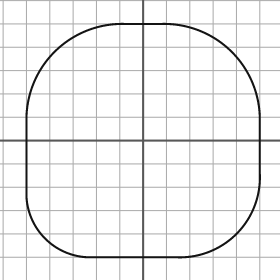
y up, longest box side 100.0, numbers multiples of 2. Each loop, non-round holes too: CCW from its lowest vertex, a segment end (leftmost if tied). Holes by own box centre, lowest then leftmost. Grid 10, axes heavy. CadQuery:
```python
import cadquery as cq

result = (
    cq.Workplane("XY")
    .moveTo(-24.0, -50.0)
    .lineTo(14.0, -50.0)
    .threePointArc((40.0, -40.0), (50.0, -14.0))
    .lineTo(50.0, 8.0)
    .threePointArc((38.0, 38.0), (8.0, 50.0))
    .lineTo(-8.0, 50.0)
    .threePointArc((-38.0, 38.0), (-50.0, 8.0))
    .lineTo(-50.0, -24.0)
    .threePointArc((-42.0, -42.0), (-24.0, -50.0))
    .close()
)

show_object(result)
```